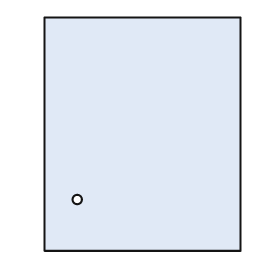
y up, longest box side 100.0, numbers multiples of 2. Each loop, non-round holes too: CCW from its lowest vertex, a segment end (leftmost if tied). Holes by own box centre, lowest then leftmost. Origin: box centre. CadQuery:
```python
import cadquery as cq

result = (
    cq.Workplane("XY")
    .moveTo(-42.0, -50.0)
    .lineTo(42.0, -50.0)
    .lineTo(42.0, 50.0)
    .lineTo(-42.0, 50.0)
    .close()
    .moveTo(-28.0, -28.0)
    .circle(2.0)
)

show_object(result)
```